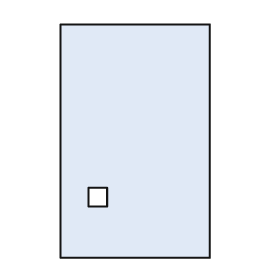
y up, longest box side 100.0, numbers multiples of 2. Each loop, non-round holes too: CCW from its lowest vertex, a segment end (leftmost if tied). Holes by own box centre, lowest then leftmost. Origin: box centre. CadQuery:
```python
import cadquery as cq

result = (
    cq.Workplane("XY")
    .moveTo(-32.0, -50.0)
    .lineTo(32.0, -50.0)
    .lineTo(32.0, 50.0)
    .lineTo(-32.0, 50.0)
    .close()
    .moveTo(-20.0, -28.0)
    .lineTo(-12.0, -28.0)
    .lineTo(-12.0, -20.0)
    .lineTo(-20.0, -20.0)
    .close()
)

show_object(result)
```